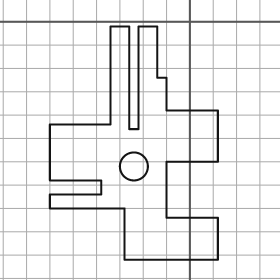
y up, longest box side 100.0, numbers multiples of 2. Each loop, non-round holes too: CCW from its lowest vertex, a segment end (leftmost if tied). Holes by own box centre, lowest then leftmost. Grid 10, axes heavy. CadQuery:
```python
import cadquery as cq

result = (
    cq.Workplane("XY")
    .moveTo(-28.0, -102.0)
    .lineTo(12.0, -102.0)
    .lineTo(12.0, -84.0)
    .lineTo(-10.0, -84.0)
    .lineTo(-10.0, -60.0)
    .lineTo(12.0, -60.0)
    .lineTo(12.0, -38.0)
    .lineTo(-10.0, -38.0)
    .lineTo(-10.0, -24.0)
    .lineTo(-14.0, -24.0)
    .lineTo(-14.0, -2.0)
    .lineTo(-22.0, -2.0)
    .lineTo(-22.0, -46.0)
    .lineTo(-26.0, -46.0)
    .lineTo(-26.0, -2.0)
    .lineTo(-34.0, -2.0)
    .lineTo(-34.0, -44.0)
    .lineTo(-60.0, -44.0)
    .lineTo(-60.0, -68.0)
    .lineTo(-38.0, -68.0)
    .lineTo(-38.0, -74.0)
    .lineTo(-60.0, -74.0)
    .lineTo(-60.0, -80.0)
    .lineTo(-28.0, -80.0)
    .close()
    .moveTo(-24.0, -62.0)
    .circle(6.0)
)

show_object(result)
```